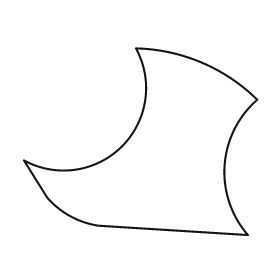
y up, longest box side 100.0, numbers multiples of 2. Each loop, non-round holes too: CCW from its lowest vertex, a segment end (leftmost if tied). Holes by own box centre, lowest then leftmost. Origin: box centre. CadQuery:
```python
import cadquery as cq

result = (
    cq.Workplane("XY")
    .moveTo(46.0, -40.0)
    .threePointArc((36.0, -10.0), (50.0, 18.0))
    .threePointArc((26.0, 34.0), (-2.0, 40.0))
    .threePointArc((-8.0, -2.0), (-50.0, -8.0))
    .lineTo(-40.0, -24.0)
    .threePointArc((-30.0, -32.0), (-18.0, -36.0))
    .close()
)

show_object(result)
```